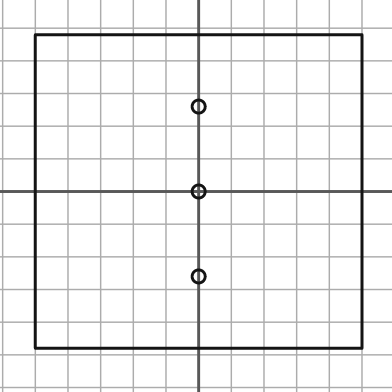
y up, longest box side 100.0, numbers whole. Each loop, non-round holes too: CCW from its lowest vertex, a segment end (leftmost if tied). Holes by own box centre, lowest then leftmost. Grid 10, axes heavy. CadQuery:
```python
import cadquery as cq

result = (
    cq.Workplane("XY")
    .moveTo(-50.0, -48.0)
    .lineTo(50.0, -48.0)
    .lineTo(50.0, 48.0)
    .lineTo(-50.0, 48.0)
    .close()
    .moveTo(0.0, -26.0)
    .circle(2.0)
    .moveTo(0.0, 0.0)
    .circle(2.0)
    .moveTo(0.0, 26.0)
    .circle(2.0)
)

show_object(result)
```